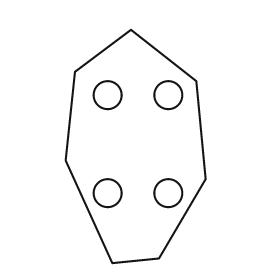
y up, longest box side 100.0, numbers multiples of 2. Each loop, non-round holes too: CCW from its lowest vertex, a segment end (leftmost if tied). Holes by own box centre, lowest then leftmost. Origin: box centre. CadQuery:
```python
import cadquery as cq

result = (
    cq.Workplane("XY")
    .moveTo(-10.0, -50.0)
    .lineTo(10.0, -48.0)
    .lineTo(30.0, -14.0)
    .lineTo(26.0, 28.0)
    .lineTo(-2.0, 50.0)
    .lineTo(-26.0, 32.0)
    .lineTo(-30.0, -6.0)
    .close()
    .moveTo(-12.0, -20.0)
    .circle(6.0)
    .moveTo(14.0, -20.0)
    .circle(6.0)
    .moveTo(-12.0, 22.0)
    .circle(6.0)
    .moveTo(14.0, 22.0)
    .circle(6.0)
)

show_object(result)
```